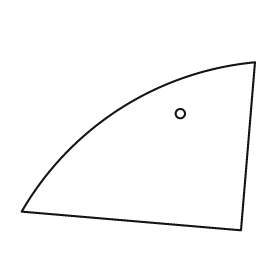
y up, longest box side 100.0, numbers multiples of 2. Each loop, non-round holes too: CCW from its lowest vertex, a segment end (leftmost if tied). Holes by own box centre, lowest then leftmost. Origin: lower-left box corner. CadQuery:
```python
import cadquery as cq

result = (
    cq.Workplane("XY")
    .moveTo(94.0, 0.0)
    .lineTo(100.0, 72.0)
    .threePointArc((42.0, 52.0), (0.0, 8.0))
    .close()
    .moveTo(68.0, 50.0)
    .circle(2.0)
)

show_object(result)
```